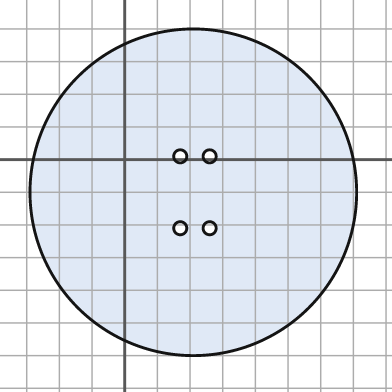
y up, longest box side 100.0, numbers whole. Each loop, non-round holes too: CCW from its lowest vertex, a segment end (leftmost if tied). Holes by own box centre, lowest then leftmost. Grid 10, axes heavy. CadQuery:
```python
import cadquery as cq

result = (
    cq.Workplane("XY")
    .moveTo(21.0, -10.0)
    .circle(50.0)
    .moveTo(17.0, -21.0)
    .circle(2.0)
    .moveTo(26.0, -21.0)
    .circle(2.0)
    .moveTo(17.0, 1.0)
    .circle(2.0)
    .moveTo(26.0, 1.0)
    .circle(2.0)
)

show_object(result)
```